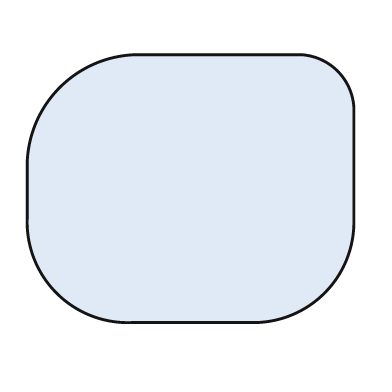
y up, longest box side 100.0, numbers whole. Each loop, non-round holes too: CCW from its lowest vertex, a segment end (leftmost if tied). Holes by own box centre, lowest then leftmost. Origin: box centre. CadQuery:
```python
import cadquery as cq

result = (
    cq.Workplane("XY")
    .moveTo(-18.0, -41.0)
    .lineTo(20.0, -41.0)
    .threePointArc((41.0, -32.0), (50.0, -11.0))
    .lineTo(50.0, 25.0)
    .threePointArc((45.0, 36.0), (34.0, 41.0))
    .lineTo(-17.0, 41.0)
    .threePointArc((-40.0, 31.0), (-50.0, 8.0))
    .lineTo(-50.0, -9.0)
    .threePointArc((-41.0, -32.0), (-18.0, -41.0))
    .close()
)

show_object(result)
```